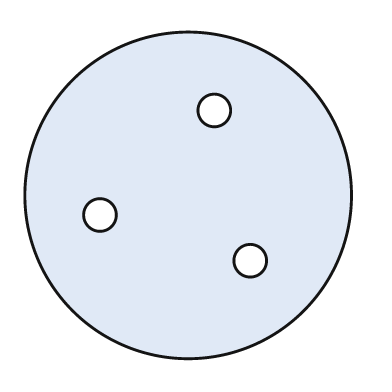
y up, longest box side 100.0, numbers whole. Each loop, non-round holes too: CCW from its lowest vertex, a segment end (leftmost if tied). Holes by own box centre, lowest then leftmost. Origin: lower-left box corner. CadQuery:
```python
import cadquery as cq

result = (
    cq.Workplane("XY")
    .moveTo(50.0, 50.0)
    .circle(50.0)
    .moveTo(69.0, 30.0)
    .circle(5.0)
    .moveTo(23.0, 44.0)
    .circle(5.0)
    .moveTo(58.0, 76.0)
    .circle(5.0)
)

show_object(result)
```